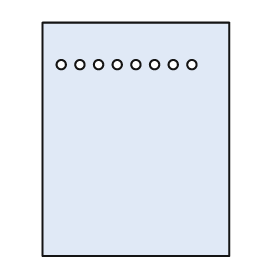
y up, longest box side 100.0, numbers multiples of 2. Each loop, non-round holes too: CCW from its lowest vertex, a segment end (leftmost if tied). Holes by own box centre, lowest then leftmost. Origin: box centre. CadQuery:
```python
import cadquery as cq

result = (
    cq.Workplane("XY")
    .moveTo(-40.0, -50.0)
    .lineTo(40.0, -50.0)
    .lineTo(40.0, 50.0)
    .lineTo(-40.0, 50.0)
    .close()
    .moveTo(-32.0, 32.0)
    .circle(2.0)
    .moveTo(-24.0, 32.0)
    .circle(2.0)
    .moveTo(-16.0, 32.0)
    .circle(2.0)
    .moveTo(-8.0, 32.0)
    .circle(2.0)
    .moveTo(0.0, 32.0)
    .circle(2.0)
    .moveTo(8.0, 32.0)
    .circle(2.0)
    .moveTo(16.0, 32.0)
    .circle(2.0)
    .moveTo(24.0, 32.0)
    .circle(2.0)
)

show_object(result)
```